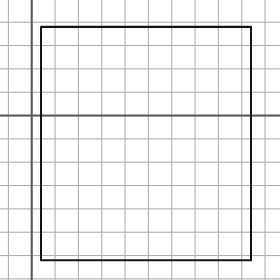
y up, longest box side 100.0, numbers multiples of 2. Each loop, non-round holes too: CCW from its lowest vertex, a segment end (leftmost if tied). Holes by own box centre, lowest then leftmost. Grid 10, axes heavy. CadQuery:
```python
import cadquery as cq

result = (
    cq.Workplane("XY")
    .moveTo(4.0, -62.0)
    .lineTo(94.0, -62.0)
    .lineTo(94.0, 38.0)
    .lineTo(4.0, 38.0)
    .close()
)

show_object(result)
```